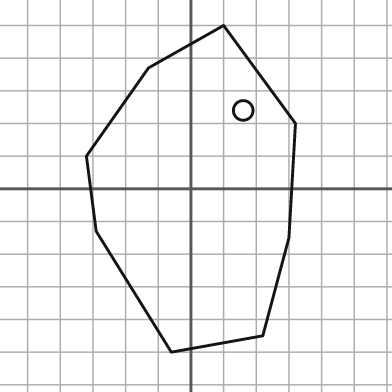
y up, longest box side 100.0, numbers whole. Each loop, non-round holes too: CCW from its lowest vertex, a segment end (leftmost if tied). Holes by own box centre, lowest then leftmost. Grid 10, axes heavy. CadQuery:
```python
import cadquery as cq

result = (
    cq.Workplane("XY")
    .moveTo(-6.0, -50.0)
    .lineTo(22.0, -45.0)
    .lineTo(30.0, -15.0)
    .lineTo(32.0, 20.0)
    .lineTo(10.0, 50.0)
    .lineTo(-13.0, 37.0)
    .lineTo(-32.0, 10.0)
    .lineTo(-29.0, -13.0)
    .close()
    .moveTo(16.0, 24.0)
    .circle(3.0)
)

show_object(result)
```